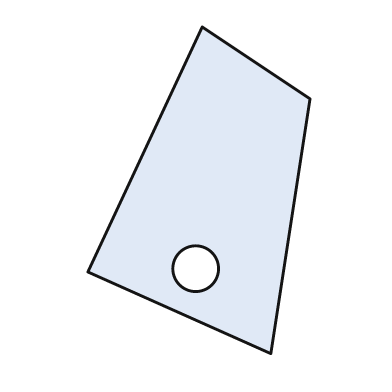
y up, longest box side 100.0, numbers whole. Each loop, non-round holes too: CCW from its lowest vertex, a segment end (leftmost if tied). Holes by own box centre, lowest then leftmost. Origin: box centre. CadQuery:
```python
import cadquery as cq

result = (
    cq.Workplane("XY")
    .moveTo(22.0, -50.0)
    .lineTo(34.0, 28.0)
    .lineTo(1.0, 50.0)
    .lineTo(-34.0, -25.0)
    .close()
    .moveTo(-1.0, -24.0)
    .circle(7.0)
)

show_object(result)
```